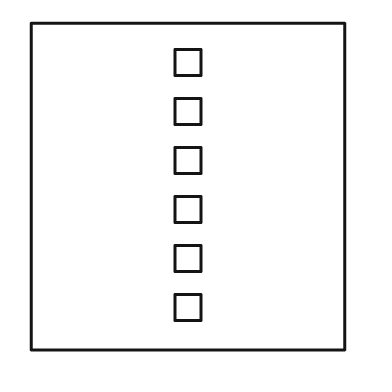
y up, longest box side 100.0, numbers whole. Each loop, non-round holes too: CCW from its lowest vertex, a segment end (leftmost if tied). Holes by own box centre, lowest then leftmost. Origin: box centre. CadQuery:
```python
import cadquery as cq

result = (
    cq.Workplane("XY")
    .moveTo(-48.0, -50.0)
    .lineTo(48.0, -50.0)
    .lineTo(48.0, 50.0)
    .lineTo(-48.0, 50.0)
    .close()
    .moveTo(-4.0, -41.0)
    .lineTo(4.0, -41.0)
    .lineTo(4.0, -33.0)
    .lineTo(-4.0, -33.0)
    .close()
    .moveTo(-4.0, -26.0)
    .lineTo(4.0, -26.0)
    .lineTo(4.0, -18.0)
    .lineTo(-4.0, -18.0)
    .close()
    .moveTo(-4.0, -11.0)
    .lineTo(4.0, -11.0)
    .lineTo(4.0, -3.0)
    .lineTo(-4.0, -3.0)
    .close()
    .moveTo(-4.0, 4.0)
    .lineTo(4.0, 4.0)
    .lineTo(4.0, 12.0)
    .lineTo(-4.0, 12.0)
    .close()
    .moveTo(-4.0, 19.0)
    .lineTo(4.0, 19.0)
    .lineTo(4.0, 27.0)
    .lineTo(-4.0, 27.0)
    .close()
    .moveTo(-4.0, 34.0)
    .lineTo(4.0, 34.0)
    .lineTo(4.0, 42.0)
    .lineTo(-4.0, 42.0)
    .close()
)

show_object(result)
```